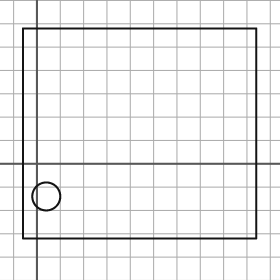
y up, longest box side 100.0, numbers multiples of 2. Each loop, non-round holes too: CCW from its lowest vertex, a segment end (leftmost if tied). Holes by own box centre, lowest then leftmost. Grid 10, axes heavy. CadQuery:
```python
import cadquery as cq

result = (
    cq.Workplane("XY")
    .moveTo(-6.0, -32.0)
    .lineTo(94.0, -32.0)
    .lineTo(94.0, 58.0)
    .lineTo(-6.0, 58.0)
    .close()
    .moveTo(4.0, -14.0)
    .circle(6.0)
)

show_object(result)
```